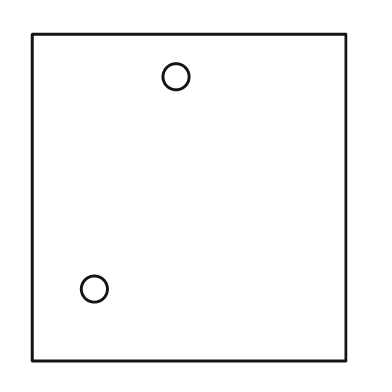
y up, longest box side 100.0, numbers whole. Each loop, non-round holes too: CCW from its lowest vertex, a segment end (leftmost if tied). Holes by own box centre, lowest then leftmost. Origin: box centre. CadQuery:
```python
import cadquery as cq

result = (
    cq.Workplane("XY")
    .moveTo(-48.0, -50.0)
    .lineTo(48.0, -50.0)
    .lineTo(48.0, 50.0)
    .lineTo(-48.0, 50.0)
    .close()
    .moveTo(-29.0, -28.0)
    .circle(4.0)
    .moveTo(-4.0, 37.0)
    .circle(4.0)
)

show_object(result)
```